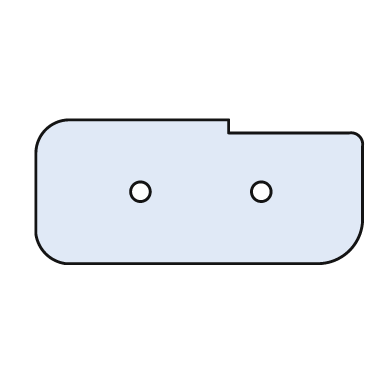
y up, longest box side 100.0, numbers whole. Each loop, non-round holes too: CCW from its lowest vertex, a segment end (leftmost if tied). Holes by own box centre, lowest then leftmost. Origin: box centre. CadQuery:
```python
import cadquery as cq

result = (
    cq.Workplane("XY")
    .moveTo(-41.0, -22.0)
    .lineTo(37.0, -22.0)
    .threePointArc((46.0, -18.0), (50.0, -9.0))
    .lineTo(50.0, 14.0)
    .threePointArc((49.0, 17.0), (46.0, 18.0))
    .lineTo(9.0, 18.0)
    .lineTo(9.0, 22.0)
    .lineTo(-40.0, 22.0)
    .threePointArc((-47.0, 19.0), (-50.0, 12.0))
    .lineTo(-50.0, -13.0)
    .threePointArc((-47.0, -19.0), (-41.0, -22.0))
    .close()
    .moveTo(-18.0, 0.0)
    .circle(3.0)
    .moveTo(19.0, 0.0)
    .circle(3.0)
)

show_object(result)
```